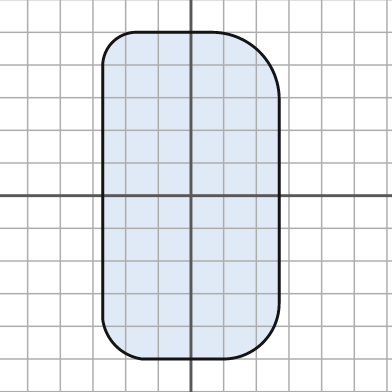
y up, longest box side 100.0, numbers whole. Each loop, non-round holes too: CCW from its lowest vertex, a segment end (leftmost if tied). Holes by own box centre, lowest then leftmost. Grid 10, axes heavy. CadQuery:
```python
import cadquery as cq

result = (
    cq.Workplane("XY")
    .moveTo(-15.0, -50.0)
    .lineTo(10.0, -50.0)
    .threePointArc((22.0, -45.0), (27.0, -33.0))
    .lineTo(27.0, 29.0)
    .threePointArc((21.0, 44.0), (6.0, 50.0))
    .lineTo(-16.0, 50.0)
    .threePointArc((-24.0, 47.0), (-27.0, 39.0))
    .lineTo(-27.0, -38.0)
    .threePointArc((-23.0, -46.0), (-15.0, -50.0))
    .close()
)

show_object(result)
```